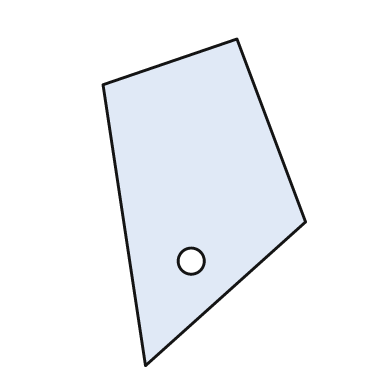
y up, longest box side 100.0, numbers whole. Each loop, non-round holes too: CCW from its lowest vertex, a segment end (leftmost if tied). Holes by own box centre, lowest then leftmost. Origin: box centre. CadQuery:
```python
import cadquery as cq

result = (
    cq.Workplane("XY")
    .moveTo(-18.0, -50.0)
    .lineTo(31.0, -6.0)
    .lineTo(10.0, 50.0)
    .lineTo(-31.0, 36.0)
    .close()
    .moveTo(-4.0, -18.0)
    .circle(4.0)
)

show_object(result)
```